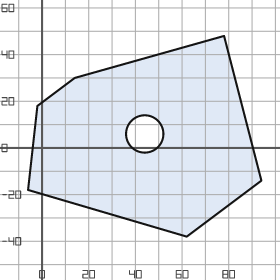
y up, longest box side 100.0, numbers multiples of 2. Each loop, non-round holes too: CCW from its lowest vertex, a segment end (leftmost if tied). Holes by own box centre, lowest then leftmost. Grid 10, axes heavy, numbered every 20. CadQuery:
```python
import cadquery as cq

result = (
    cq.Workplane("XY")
    .moveTo(62.0, -38.0)
    .lineTo(94.0, -14.0)
    .lineTo(78.0, 48.0)
    .lineTo(14.0, 30.0)
    .lineTo(-2.0, 18.0)
    .lineTo(-6.0, -18.0)
    .close()
    .moveTo(44.0, 6.0)
    .circle(8.0)
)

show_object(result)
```